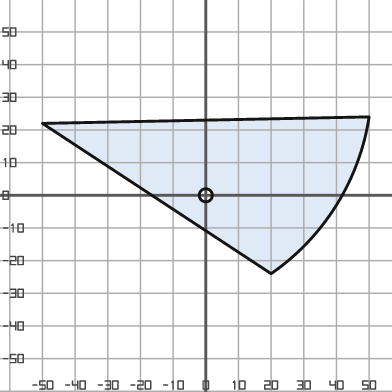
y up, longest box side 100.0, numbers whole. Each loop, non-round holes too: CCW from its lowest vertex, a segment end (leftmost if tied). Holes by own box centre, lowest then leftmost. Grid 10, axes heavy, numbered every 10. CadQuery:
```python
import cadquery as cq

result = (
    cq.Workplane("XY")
    .moveTo(20.0, -24.0)
    .threePointArc((40.0, -3.0), (50.0, 24.0))
    .lineTo(-50.0, 22.0)
    .close()
    .moveTo(0.0, 0.0)
    .circle(2.0)
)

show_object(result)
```